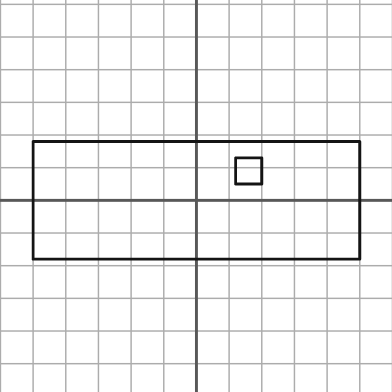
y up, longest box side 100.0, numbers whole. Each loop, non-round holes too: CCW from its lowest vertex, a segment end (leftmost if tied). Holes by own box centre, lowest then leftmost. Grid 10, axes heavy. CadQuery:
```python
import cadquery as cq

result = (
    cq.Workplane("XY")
    .moveTo(-50.0, -18.0)
    .lineTo(50.0, -18.0)
    .lineTo(50.0, 18.0)
    .lineTo(-50.0, 18.0)
    .close()
    .moveTo(12.0, 5.0)
    .lineTo(20.0, 5.0)
    .lineTo(20.0, 13.0)
    .lineTo(12.0, 13.0)
    .close()
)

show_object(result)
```